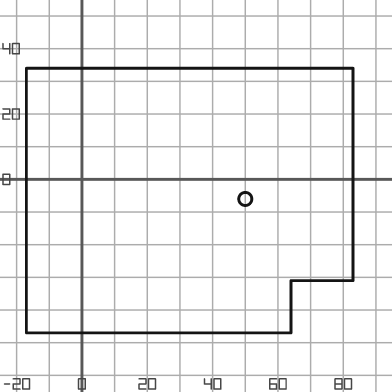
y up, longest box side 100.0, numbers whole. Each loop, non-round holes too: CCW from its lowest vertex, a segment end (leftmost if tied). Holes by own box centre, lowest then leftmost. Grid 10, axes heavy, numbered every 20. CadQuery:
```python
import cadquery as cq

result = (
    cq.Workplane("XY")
    .moveTo(-17.0, -47.0)
    .lineTo(64.0, -47.0)
    .lineTo(64.0, -31.0)
    .lineTo(83.0, -31.0)
    .lineTo(83.0, 34.0)
    .lineTo(-17.0, 34.0)
    .close()
    .moveTo(50.0, -6.0)
    .circle(2.0)
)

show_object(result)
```